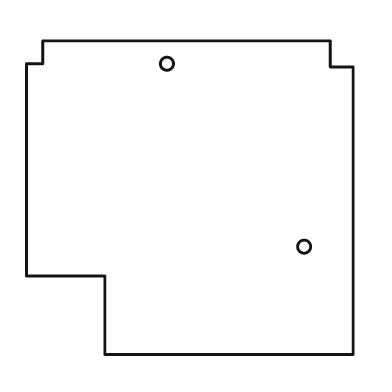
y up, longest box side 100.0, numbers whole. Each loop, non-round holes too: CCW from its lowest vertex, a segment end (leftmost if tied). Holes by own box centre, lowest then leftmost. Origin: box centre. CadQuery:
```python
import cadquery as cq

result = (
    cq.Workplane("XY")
    .moveTo(-26.0, -48.0)
    .lineTo(50.0, -48.0)
    .lineTo(50.0, 40.0)
    .lineTo(43.0, 40.0)
    .lineTo(43.0, 48.0)
    .lineTo(-45.0, 48.0)
    .lineTo(-45.0, 41.0)
    .lineTo(-50.0, 41.0)
    .lineTo(-50.0, -24.0)
    .lineTo(-26.0, -24.0)
    .close()
    .moveTo(35.0, -15.0)
    .circle(2.0)
    .moveTo(-7.0, 41.0)
    .circle(2.0)
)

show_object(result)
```